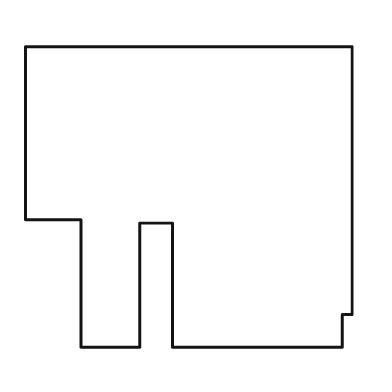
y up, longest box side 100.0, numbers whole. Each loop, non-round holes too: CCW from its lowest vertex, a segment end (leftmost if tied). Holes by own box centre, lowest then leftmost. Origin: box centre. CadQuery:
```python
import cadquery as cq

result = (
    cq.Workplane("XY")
    .moveTo(-33.0, -46.0)
    .lineTo(-15.0, -46.0)
    .lineTo(-15.0, -8.0)
    .lineTo(-5.0, -8.0)
    .lineTo(-5.0, -46.0)
    .lineTo(47.0, -46.0)
    .lineTo(47.0, -36.0)
    .lineTo(50.0, -36.0)
    .lineTo(50.0, 46.0)
    .lineTo(-50.0, 46.0)
    .lineTo(-50.0, -7.0)
    .lineTo(-33.0, -7.0)
    .close()
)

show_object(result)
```